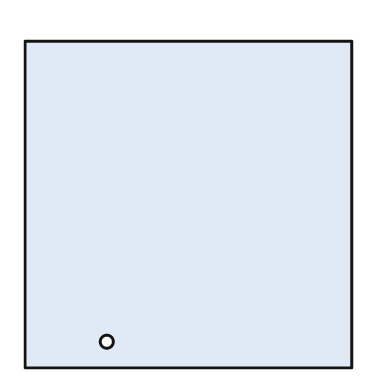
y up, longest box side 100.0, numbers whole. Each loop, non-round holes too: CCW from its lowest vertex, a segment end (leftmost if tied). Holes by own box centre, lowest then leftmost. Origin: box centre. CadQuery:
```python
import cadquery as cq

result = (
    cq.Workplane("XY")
    .moveTo(-50.0, -50.0)
    .lineTo(50.0, -50.0)
    .lineTo(50.0, 50.0)
    .lineTo(-50.0, 50.0)
    .close()
    .moveTo(-25.0, -42.0)
    .circle(2.0)
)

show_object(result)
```